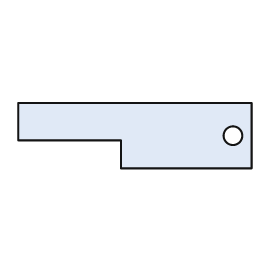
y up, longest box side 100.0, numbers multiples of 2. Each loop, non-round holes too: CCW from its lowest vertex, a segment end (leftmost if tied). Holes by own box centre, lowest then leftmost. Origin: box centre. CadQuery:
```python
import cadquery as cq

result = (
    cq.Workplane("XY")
    .moveTo(-6.0, -14.0)
    .lineTo(50.0, -14.0)
    .lineTo(50.0, 14.0)
    .lineTo(-50.0, 14.0)
    .lineTo(-50.0, -2.0)
    .lineTo(-6.0, -2.0)
    .close()
    .moveTo(42.0, 0.0)
    .circle(4.0)
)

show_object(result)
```